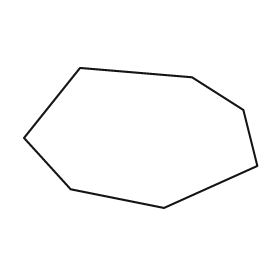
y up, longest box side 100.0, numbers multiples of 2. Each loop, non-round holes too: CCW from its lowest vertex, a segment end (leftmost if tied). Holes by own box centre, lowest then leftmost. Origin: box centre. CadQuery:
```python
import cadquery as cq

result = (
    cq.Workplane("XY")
    .moveTo(10.0, -30.0)
    .lineTo(50.0, -12.0)
    .lineTo(44.0, 12.0)
    .lineTo(22.0, 26.0)
    .lineTo(-26.0, 30.0)
    .lineTo(-50.0, 0.0)
    .lineTo(-30.0, -22.0)
    .close()
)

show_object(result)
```